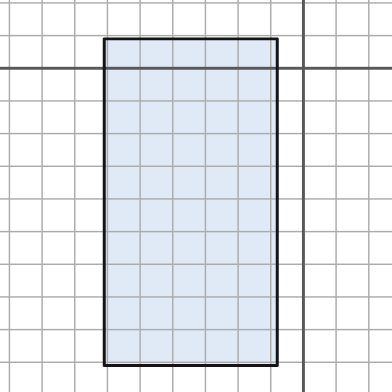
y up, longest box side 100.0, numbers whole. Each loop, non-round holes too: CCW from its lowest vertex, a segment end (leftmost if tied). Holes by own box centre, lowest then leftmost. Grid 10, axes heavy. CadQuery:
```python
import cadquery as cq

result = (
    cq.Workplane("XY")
    .moveTo(-61.0, -91.0)
    .lineTo(-8.0, -91.0)
    .lineTo(-8.0, 9.0)
    .lineTo(-61.0, 9.0)
    .close()
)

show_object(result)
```